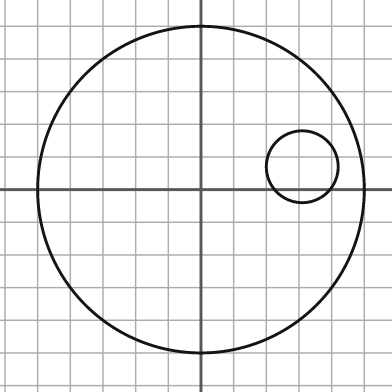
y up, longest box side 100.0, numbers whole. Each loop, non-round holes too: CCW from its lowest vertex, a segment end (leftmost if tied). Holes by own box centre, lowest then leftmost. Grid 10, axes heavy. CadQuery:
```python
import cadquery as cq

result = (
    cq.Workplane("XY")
    .moveTo(0.0, 0.0)
    .circle(50.0)
    .moveTo(31.0, 7.0)
    .circle(11.0)
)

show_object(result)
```